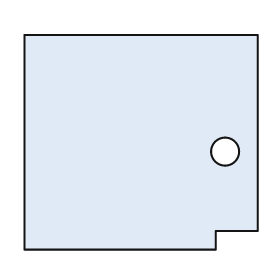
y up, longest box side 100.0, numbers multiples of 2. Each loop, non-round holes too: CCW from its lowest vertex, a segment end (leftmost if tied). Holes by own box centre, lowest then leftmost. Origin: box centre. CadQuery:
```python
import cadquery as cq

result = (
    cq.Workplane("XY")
    .moveTo(-50.0, -46.0)
    .lineTo(32.0, -46.0)
    .lineTo(32.0, -38.0)
    .lineTo(50.0, -38.0)
    .lineTo(50.0, 46.0)
    .lineTo(-50.0, 46.0)
    .close()
    .moveTo(36.0, -4.0)
    .circle(6.0)
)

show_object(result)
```